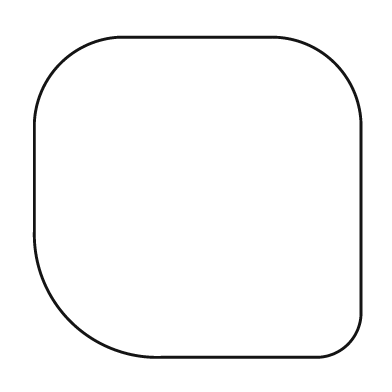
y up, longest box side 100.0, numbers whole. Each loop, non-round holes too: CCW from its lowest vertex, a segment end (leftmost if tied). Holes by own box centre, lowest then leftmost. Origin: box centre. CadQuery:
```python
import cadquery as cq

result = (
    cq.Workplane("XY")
    .moveTo(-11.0, -49.0)
    .lineTo(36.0, -49.0)
    .threePointArc((46.0, -45.0), (50.0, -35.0))
    .lineTo(50.0, 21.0)
    .threePointArc((42.0, 41.0), (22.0, 49.0))
    .lineTo(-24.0, 49.0)
    .threePointArc((-42.0, 41.0), (-50.0, 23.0))
    .lineTo(-50.0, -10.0)
    .threePointArc((-39.0, -38.0), (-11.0, -49.0))
    .close()
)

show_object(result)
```